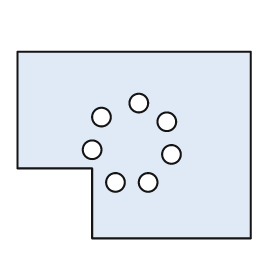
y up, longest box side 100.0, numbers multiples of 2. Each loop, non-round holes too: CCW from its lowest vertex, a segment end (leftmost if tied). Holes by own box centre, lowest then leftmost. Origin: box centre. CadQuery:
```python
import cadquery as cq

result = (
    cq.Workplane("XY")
    .moveTo(-18.0, -40.0)
    .lineTo(50.0, -40.0)
    .lineTo(50.0, 40.0)
    .lineTo(-50.0, 40.0)
    .lineTo(-50.0, -10.0)
    .lineTo(-18.0, -10.0)
    .close()
    .moveTo(-8.0, -16.0)
    .circle(4.0)
    .moveTo(6.0, -16.0)
    .circle(4.0)
    .moveTo(16.0, -4.0)
    .circle(4.0)
    .moveTo(-18.0, -2.0)
    .circle(4.0)
    .moveTo(14.0, 10.0)
    .circle(4.0)
    .moveTo(-14.0, 12.0)
    .circle(4.0)
    .moveTo(2.0, 18.0)
    .circle(4.0)
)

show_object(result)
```